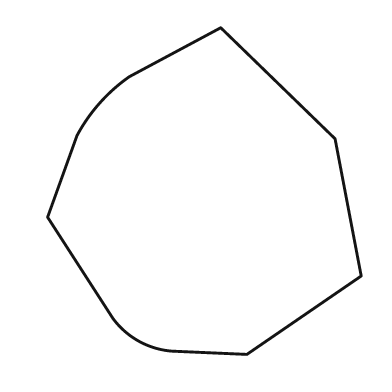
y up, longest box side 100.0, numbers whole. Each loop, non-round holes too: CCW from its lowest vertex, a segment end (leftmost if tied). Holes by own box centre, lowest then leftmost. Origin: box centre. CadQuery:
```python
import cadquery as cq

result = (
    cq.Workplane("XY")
    .moveTo(13.0, -50.0)
    .lineTo(48.0, -26.0)
    .lineTo(40.0, 16.0)
    .lineTo(5.0, 50.0)
    .lineTo(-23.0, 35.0)
    .threePointArc((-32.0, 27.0), (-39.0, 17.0))
    .lineTo(-48.0, -8.0)
    .lineTo(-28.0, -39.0)
    .threePointArc((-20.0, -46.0), (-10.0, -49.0))
    .close()
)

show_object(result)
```